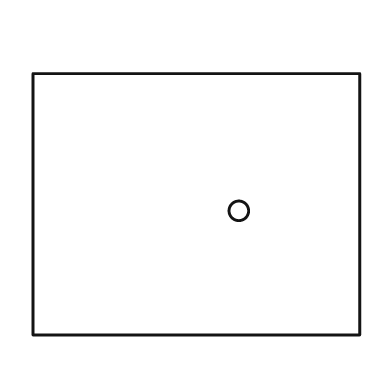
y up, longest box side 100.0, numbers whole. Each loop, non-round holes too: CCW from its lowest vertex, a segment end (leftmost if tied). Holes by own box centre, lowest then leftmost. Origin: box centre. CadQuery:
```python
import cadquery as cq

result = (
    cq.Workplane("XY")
    .moveTo(-50.0, -40.0)
    .lineTo(50.0, -40.0)
    .lineTo(50.0, 40.0)
    .lineTo(-50.0, 40.0)
    .close()
    .moveTo(13.0, -2.0)
    .circle(3.0)
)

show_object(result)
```